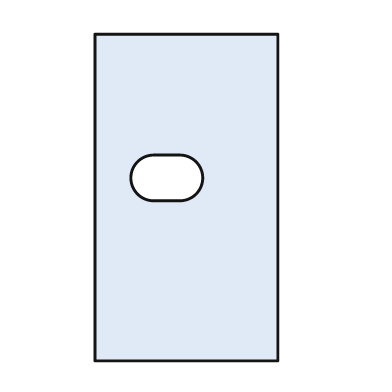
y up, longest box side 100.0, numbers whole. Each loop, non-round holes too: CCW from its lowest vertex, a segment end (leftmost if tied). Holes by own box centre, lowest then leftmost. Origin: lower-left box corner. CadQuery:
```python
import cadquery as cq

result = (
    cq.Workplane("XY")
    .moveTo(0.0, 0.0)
    .lineTo(56.0, 0.0)
    .lineTo(56.0, 100.0)
    .lineTo(0.0, 100.0)
    .close()
    .moveTo(18.0, 49.0)
    .lineTo(26.0, 49.0)
    .threePointArc((33.0, 56.0), (26.0, 63.0))
    .lineTo(18.0, 63.0)
    .threePointArc((11.0, 56.0), (18.0, 49.0))
    .close()
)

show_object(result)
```